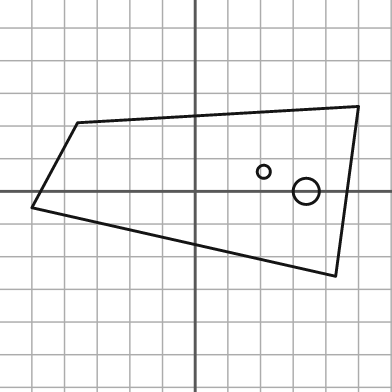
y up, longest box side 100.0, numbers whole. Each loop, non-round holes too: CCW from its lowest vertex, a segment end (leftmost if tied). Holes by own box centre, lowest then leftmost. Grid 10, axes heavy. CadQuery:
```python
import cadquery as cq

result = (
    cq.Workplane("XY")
    .moveTo(43.0, -26.0)
    .lineTo(50.0, 26.0)
    .lineTo(-36.0, 21.0)
    .lineTo(-50.0, -5.0)
    .close()
    .moveTo(34.0, 0.0)
    .circle(4.0)
    .moveTo(21.0, 6.0)
    .circle(2.0)
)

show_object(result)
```